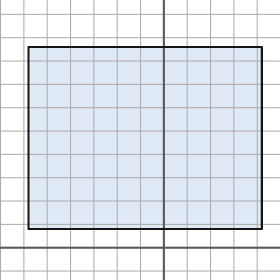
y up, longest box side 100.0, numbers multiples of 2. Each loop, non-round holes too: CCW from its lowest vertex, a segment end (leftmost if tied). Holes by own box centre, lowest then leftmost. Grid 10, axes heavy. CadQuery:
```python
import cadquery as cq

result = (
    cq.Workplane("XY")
    .moveTo(-58.0, 8.0)
    .lineTo(42.0, 8.0)
    .lineTo(42.0, 86.0)
    .lineTo(-58.0, 86.0)
    .close()
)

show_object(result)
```